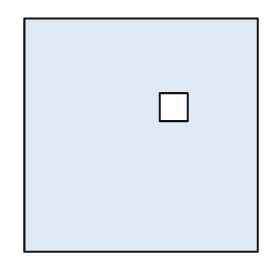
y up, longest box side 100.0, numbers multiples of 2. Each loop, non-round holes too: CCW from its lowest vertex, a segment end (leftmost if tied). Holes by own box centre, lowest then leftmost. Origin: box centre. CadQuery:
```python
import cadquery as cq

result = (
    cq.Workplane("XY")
    .moveTo(-50.0, -50.0)
    .lineTo(50.0, -50.0)
    .lineTo(50.0, 50.0)
    .lineTo(-50.0, 50.0)
    .close()
    .moveTo(8.0, 6.0)
    .lineTo(20.0, 6.0)
    .lineTo(20.0, 18.0)
    .lineTo(8.0, 18.0)
    .close()
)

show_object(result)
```